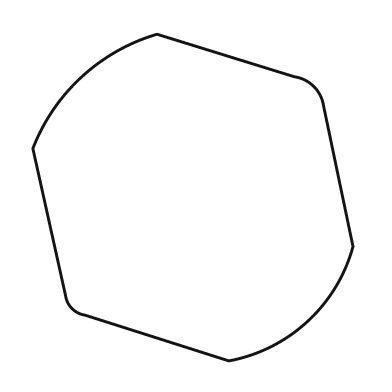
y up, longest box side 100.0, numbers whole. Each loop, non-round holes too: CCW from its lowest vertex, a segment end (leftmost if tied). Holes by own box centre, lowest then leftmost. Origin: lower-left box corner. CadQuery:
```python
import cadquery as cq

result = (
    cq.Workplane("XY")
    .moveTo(60.0, 0.0)
    .threePointArc((84.0, 12.0), (98.0, 35.0))
    .lineTo(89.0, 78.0)
    .threePointArc((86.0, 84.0), (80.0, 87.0))
    .lineTo(38.0, 100.0)
    .threePointArc((15.0, 87.0), (0.0, 65.0))
    .lineTo(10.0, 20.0)
    .threePointArc((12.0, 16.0), (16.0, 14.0))
    .close()
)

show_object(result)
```